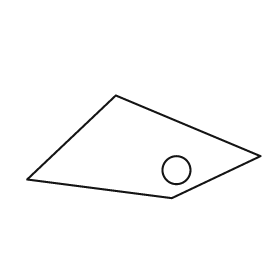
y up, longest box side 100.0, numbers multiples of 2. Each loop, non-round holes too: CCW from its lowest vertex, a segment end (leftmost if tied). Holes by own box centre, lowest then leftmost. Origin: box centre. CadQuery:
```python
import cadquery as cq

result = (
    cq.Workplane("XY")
    .moveTo(12.0, -22.0)
    .lineTo(50.0, -4.0)
    .lineTo(-12.0, 22.0)
    .lineTo(-50.0, -14.0)
    .close()
    .moveTo(14.0, -10.0)
    .circle(6.0)
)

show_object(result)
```